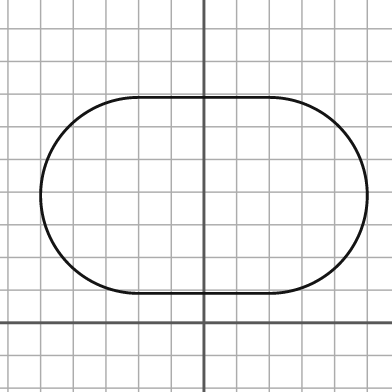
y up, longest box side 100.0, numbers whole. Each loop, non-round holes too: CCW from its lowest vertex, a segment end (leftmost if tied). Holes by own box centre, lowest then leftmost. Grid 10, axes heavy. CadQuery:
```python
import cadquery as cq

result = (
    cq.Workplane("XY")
    .moveTo(-20.0, 9.0)
    .lineTo(20.0, 9.0)
    .threePointArc((50.0, 39.0), (20.0, 69.0))
    .lineTo(-20.0, 69.0)
    .threePointArc((-50.0, 39.0), (-20.0, 9.0))
    .close()
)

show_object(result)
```